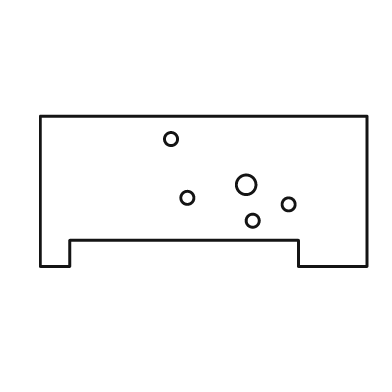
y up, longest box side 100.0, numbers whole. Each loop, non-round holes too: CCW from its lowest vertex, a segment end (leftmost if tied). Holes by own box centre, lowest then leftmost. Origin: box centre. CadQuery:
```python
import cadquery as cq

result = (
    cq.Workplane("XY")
    .moveTo(-50.0, -23.0)
    .lineTo(-41.0, -23.0)
    .lineTo(-41.0, -15.0)
    .lineTo(29.0, -15.0)
    .lineTo(29.0, -23.0)
    .lineTo(50.0, -23.0)
    .lineTo(50.0, 23.0)
    .lineTo(-50.0, 23.0)
    .close()
    .moveTo(15.0, -9.0)
    .circle(2.0)
    .moveTo(26.0, -4.0)
    .circle(2.0)
    .moveTo(-5.0, -2.0)
    .circle(2.0)
    .moveTo(13.0, 2.0)
    .circle(3.0)
    .moveTo(-10.0, 16.0)
    .circle(2.0)
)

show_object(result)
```